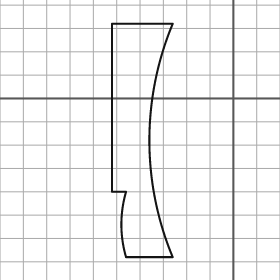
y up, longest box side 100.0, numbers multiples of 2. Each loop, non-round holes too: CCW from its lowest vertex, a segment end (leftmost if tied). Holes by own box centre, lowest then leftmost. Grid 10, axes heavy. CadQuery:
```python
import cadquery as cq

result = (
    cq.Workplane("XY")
    .moveTo(-46.0, -68.0)
    .lineTo(-26.0, -68.0)
    .threePointArc((-36.0, -18.0), (-26.0, 32.0))
    .lineTo(-52.0, 32.0)
    .lineTo(-52.0, -40.0)
    .lineTo(-46.0, -40.0)
    .threePointArc((-48.0, -54.0), (-46.0, -68.0))
    .close()
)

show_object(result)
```